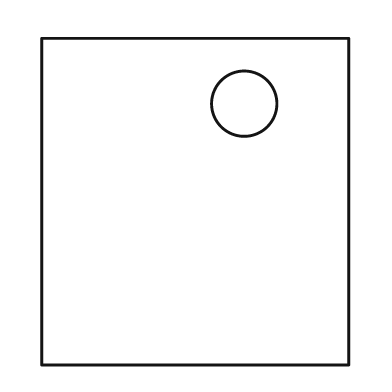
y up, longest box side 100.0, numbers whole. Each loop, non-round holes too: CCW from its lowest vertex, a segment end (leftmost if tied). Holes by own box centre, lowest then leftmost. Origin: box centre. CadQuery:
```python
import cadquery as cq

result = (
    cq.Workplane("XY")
    .moveTo(-47.0, -50.0)
    .lineTo(47.0, -50.0)
    .lineTo(47.0, 50.0)
    .lineTo(-47.0, 50.0)
    .close()
    .moveTo(15.0, 30.0)
    .circle(10.0)
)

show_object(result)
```